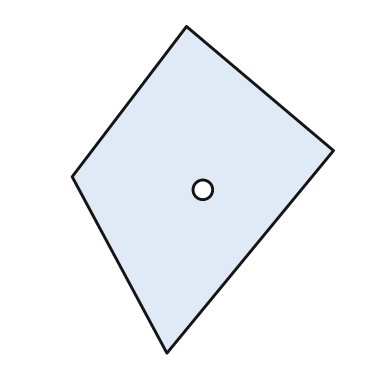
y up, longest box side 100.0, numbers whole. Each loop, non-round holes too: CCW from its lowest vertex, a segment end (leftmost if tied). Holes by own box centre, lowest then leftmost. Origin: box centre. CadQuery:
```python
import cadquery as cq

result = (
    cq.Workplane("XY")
    .moveTo(-11.0, -50.0)
    .lineTo(40.0, 12.0)
    .lineTo(-5.0, 50.0)
    .lineTo(-40.0, 4.0)
    .close()
    .moveTo(0.0, 0.0)
    .circle(3.0)
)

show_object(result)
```